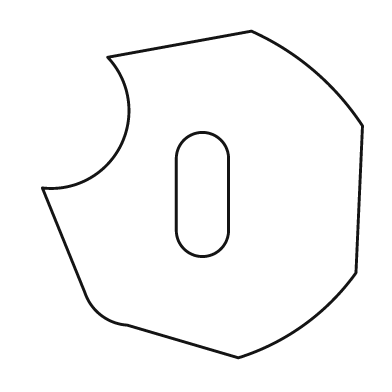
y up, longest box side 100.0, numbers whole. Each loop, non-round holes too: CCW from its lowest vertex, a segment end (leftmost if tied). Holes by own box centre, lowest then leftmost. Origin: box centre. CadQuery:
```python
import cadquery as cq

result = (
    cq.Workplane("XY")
    .moveTo(11.0, -50.0)
    .threePointArc((31.0, -40.0), (47.0, -24.0))
    .lineTo(49.0, 21.0)
    .threePointArc((34.0, 38.0), (15.0, 50.0))
    .lineTo(-29.0, 42.0)
    .threePointArc((-25.0, 15.0), (-49.0, 2.0))
    .lineTo(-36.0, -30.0)
    .threePointArc((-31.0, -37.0), (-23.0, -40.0))
    .close()
    .moveTo(-8.0, -11.0)
    .threePointArc((0.0, -19.0), (8.0, -11.0))
    .lineTo(8.0, 11.0)
    .threePointArc((0.0, 19.0), (-8.0, 11.0))
    .close()
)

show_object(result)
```